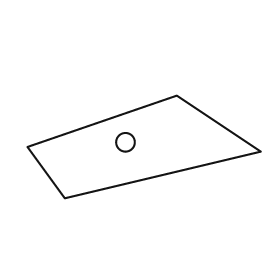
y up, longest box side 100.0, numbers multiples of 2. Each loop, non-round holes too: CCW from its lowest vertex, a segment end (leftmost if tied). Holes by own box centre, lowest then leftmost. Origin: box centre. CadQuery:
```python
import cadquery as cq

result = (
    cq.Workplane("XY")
    .moveTo(-34.0, -22.0)
    .lineTo(50.0, -2.0)
    .lineTo(14.0, 22.0)
    .lineTo(-50.0, 0.0)
    .close()
    .moveTo(-8.0, 2.0)
    .circle(4.0)
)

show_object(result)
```